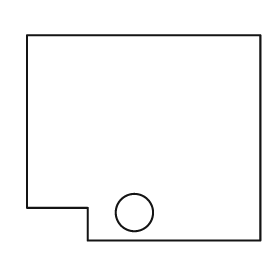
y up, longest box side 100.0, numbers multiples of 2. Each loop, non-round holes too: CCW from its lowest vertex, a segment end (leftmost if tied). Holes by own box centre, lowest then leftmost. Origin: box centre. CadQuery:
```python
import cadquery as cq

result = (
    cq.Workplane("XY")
    .moveTo(-24.0, -44.0)
    .lineTo(50.0, -44.0)
    .lineTo(50.0, 44.0)
    .lineTo(-50.0, 44.0)
    .lineTo(-50.0, -30.0)
    .lineTo(-24.0, -30.0)
    .close()
    .moveTo(-4.0, -32.0)
    .circle(8.0)
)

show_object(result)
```